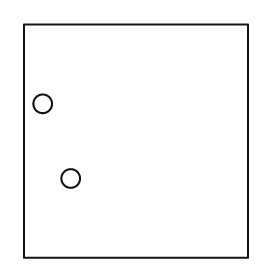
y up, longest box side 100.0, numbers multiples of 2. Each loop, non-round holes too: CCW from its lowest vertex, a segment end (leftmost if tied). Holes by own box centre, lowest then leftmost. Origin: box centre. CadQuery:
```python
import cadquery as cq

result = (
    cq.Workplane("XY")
    .moveTo(-48.0, -50.0)
    .lineTo(48.0, -50.0)
    .lineTo(48.0, 50.0)
    .lineTo(-48.0, 50.0)
    .close()
    .moveTo(-28.0, -16.0)
    .circle(4.0)
    .moveTo(-40.0, 16.0)
    .circle(4.0)
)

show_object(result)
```